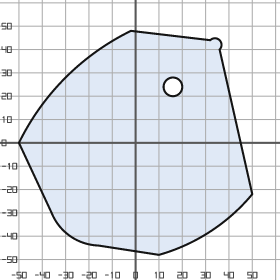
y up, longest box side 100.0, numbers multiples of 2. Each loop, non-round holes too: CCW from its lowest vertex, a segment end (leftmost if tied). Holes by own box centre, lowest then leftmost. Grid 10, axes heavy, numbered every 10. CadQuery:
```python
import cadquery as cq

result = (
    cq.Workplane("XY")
    .moveTo(10.0, -48.0)
    .threePointArc((32.0, -38.0), (50.0, -22.0))
    .lineTo(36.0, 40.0)
    .threePointArc((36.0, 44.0), (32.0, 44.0))
    .lineTo(-2.0, 48.0)
    .threePointArc((-30.0, 28.0), (-50.0, 0.0))
    .lineTo(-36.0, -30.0)
    .threePointArc((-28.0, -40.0), (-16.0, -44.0))
    .close()
    .moveTo(16.0, 24.0)
    .circle(4.0)
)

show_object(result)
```